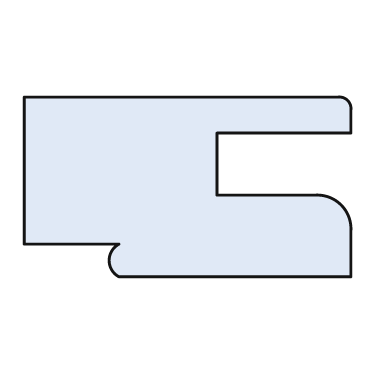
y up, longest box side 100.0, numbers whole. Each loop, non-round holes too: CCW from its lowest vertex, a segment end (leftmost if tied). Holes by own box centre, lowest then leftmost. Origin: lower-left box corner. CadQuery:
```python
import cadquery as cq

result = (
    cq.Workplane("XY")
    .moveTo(29.0, 0.0)
    .lineTo(100.0, 0.0)
    .lineTo(100.0, 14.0)
    .threePointArc((97.0, 22.0), (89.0, 25.0))
    .lineTo(59.0, 25.0)
    .lineTo(59.0, 44.0)
    .lineTo(100.0, 44.0)
    .lineTo(100.0, 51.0)
    .threePointArc((99.0, 54.0), (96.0, 55.0))
    .lineTo(0.0, 55.0)
    .lineTo(0.0, 10.0)
    .lineTo(29.0, 10.0)
    .threePointArc((26.0, 5.0), (29.0, 0.0))
    .close()
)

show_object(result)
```